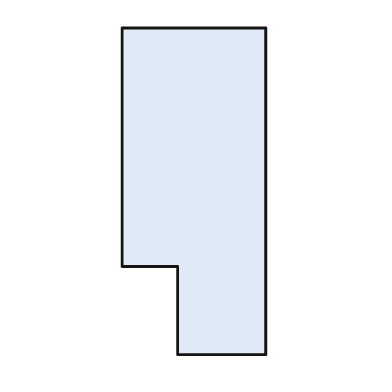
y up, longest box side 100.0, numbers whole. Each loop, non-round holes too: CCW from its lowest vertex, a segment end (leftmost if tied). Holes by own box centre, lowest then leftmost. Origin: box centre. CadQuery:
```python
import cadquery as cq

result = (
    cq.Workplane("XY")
    .moveTo(-5.0, -50.0)
    .lineTo(22.0, -50.0)
    .lineTo(22.0, 50.0)
    .lineTo(-22.0, 50.0)
    .lineTo(-22.0, -23.0)
    .lineTo(-5.0, -23.0)
    .close()
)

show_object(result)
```